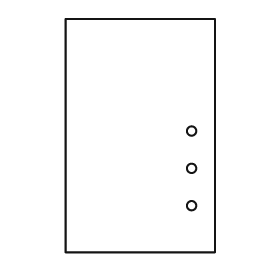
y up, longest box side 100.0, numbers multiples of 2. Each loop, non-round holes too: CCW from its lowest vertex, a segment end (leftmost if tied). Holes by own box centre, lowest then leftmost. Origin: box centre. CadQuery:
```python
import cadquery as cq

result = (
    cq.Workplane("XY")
    .moveTo(-32.0, -50.0)
    .lineTo(32.0, -50.0)
    .lineTo(32.0, 50.0)
    .lineTo(-32.0, 50.0)
    .close()
    .moveTo(22.0, -30.0)
    .circle(2.0)
    .moveTo(22.0, -14.0)
    .circle(2.0)
    .moveTo(22.0, 2.0)
    .circle(2.0)
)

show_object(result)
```